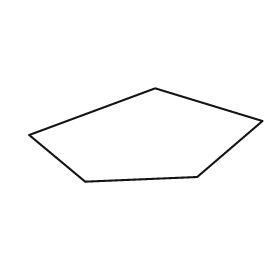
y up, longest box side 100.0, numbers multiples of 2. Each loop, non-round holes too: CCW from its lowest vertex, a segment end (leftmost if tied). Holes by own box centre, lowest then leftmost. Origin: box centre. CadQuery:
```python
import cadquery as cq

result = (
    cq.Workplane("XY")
    .moveTo(-26.0, -20.0)
    .lineTo(22.0, -18.0)
    .lineTo(50.0, 6.0)
    .lineTo(4.0, 20.0)
    .lineTo(-50.0, 0.0)
    .close()
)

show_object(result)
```